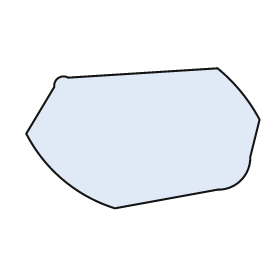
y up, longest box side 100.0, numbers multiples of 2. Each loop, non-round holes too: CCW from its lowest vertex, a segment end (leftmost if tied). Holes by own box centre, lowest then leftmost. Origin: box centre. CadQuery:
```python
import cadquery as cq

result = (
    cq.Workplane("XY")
    .moveTo(-12.0, -30.0)
    .lineTo(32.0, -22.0)
    .threePointArc((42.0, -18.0), (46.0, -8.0))
    .lineTo(50.0, 8.0)
    .threePointArc((42.0, 20.0), (32.0, 30.0))
    .lineTo(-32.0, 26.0)
    .threePointArc((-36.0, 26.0), (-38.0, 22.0))
    .lineTo(-50.0, 2.0)
    .threePointArc((-34.0, -18.0), (-12.0, -30.0))
    .close()
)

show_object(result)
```